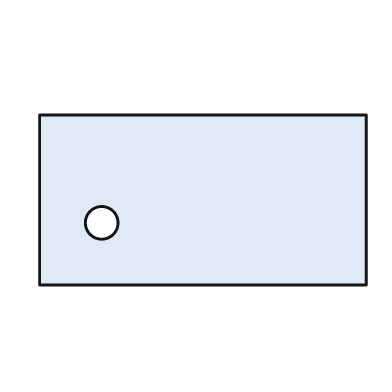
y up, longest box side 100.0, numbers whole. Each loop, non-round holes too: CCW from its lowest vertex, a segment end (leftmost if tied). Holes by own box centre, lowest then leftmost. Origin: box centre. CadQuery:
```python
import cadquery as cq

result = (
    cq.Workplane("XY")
    .moveTo(-50.0, -26.0)
    .lineTo(50.0, -26.0)
    .lineTo(50.0, 26.0)
    .lineTo(-50.0, 26.0)
    .close()
    .moveTo(-31.0, -7.0)
    .circle(5.0)
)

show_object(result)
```